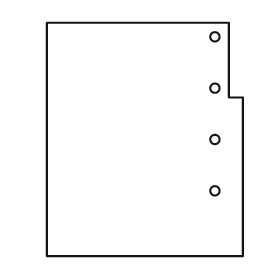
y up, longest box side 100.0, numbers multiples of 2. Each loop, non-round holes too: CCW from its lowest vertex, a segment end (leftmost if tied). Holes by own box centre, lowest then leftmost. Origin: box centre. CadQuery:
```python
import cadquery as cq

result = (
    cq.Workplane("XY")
    .moveTo(-42.0, -50.0)
    .lineTo(42.0, -50.0)
    .lineTo(42.0, 18.0)
    .lineTo(36.0, 18.0)
    .lineTo(36.0, 50.0)
    .lineTo(-42.0, 50.0)
    .close()
    .moveTo(30.0, -22.0)
    .circle(2.0)
    .moveTo(30.0, 0.0)
    .circle(2.0)
    .moveTo(30.0, 22.0)
    .circle(2.0)
    .moveTo(30.0, 44.0)
    .circle(2.0)
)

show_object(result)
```